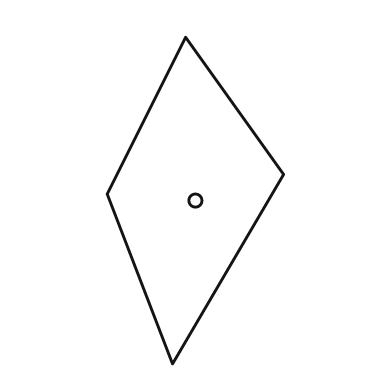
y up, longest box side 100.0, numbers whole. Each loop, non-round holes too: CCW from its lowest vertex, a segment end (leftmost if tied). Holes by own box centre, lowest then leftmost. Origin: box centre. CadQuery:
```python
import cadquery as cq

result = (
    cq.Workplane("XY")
    .moveTo(-7.0, -50.0)
    .lineTo(27.0, 8.0)
    .lineTo(-3.0, 50.0)
    .lineTo(-27.0, 2.0)
    .close()
    .moveTo(0.0, 0.0)
    .circle(2.0)
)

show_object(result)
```